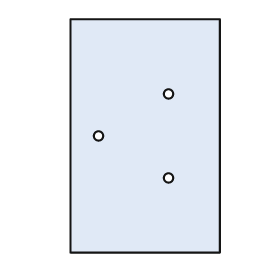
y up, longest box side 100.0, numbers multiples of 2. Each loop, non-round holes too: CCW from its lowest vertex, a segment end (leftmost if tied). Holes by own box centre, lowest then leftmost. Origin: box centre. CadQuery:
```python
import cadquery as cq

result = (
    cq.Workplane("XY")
    .moveTo(-32.0, -50.0)
    .lineTo(32.0, -50.0)
    .lineTo(32.0, 50.0)
    .lineTo(-32.0, 50.0)
    .close()
    .moveTo(10.0, -18.0)
    .circle(2.0)
    .moveTo(-20.0, 0.0)
    .circle(2.0)
    .moveTo(10.0, 18.0)
    .circle(2.0)
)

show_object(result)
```